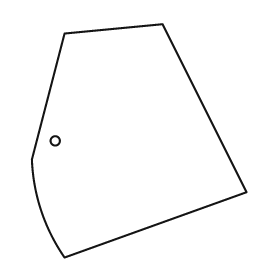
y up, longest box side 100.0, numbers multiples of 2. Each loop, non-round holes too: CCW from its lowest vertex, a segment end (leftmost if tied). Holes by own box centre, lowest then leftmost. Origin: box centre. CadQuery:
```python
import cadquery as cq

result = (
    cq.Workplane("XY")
    .moveTo(-32.0, -50.0)
    .lineTo(46.0, -22.0)
    .lineTo(10.0, 50.0)
    .lineTo(-32.0, 46.0)
    .lineTo(-46.0, -8.0)
    .threePointArc((-42.0, -30.0), (-32.0, -50.0))
    .close()
    .moveTo(-36.0, 0.0)
    .circle(2.0)
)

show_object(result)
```